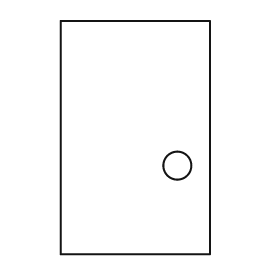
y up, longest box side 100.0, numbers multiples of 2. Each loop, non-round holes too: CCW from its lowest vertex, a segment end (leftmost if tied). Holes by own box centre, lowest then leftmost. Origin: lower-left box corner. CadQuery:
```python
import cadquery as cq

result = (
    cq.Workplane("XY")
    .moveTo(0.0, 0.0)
    .lineTo(64.0, 0.0)
    .lineTo(64.0, 100.0)
    .lineTo(0.0, 100.0)
    .close()
    .moveTo(50.0, 38.0)
    .circle(6.0)
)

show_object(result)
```